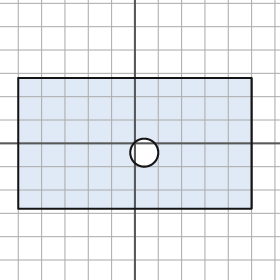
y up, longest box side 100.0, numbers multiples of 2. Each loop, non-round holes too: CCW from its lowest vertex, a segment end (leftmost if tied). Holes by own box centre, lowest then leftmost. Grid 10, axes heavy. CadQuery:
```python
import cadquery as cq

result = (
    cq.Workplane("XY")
    .moveTo(-50.0, -28.0)
    .lineTo(50.0, -28.0)
    .lineTo(50.0, 28.0)
    .lineTo(-50.0, 28.0)
    .close()
    .moveTo(4.0, -4.0)
    .circle(6.0)
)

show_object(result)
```